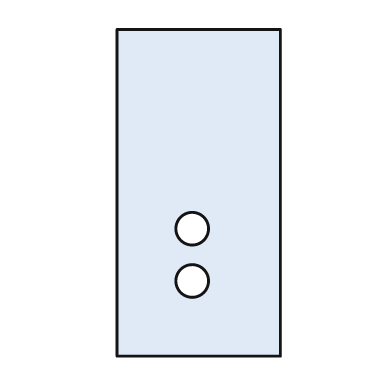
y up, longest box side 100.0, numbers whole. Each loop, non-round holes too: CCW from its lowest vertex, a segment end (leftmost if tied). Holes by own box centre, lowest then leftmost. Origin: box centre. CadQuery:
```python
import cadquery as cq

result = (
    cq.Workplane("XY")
    .moveTo(-25.0, -50.0)
    .lineTo(25.0, -50.0)
    .lineTo(25.0, 50.0)
    .lineTo(-25.0, 50.0)
    .close()
    .moveTo(-2.0, -27.0)
    .circle(5.0)
    .moveTo(-2.0, -11.0)
    .circle(5.0)
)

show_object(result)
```